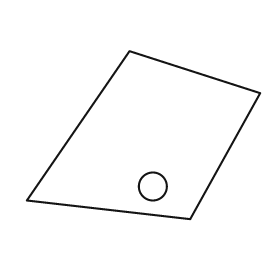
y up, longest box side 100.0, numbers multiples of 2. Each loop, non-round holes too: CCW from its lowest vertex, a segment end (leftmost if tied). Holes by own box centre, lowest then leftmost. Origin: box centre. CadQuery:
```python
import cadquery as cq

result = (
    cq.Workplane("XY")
    .moveTo(20.0, -36.0)
    .lineTo(50.0, 18.0)
    .lineTo(-6.0, 36.0)
    .lineTo(-50.0, -28.0)
    .close()
    .moveTo(4.0, -22.0)
    .circle(6.0)
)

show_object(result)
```